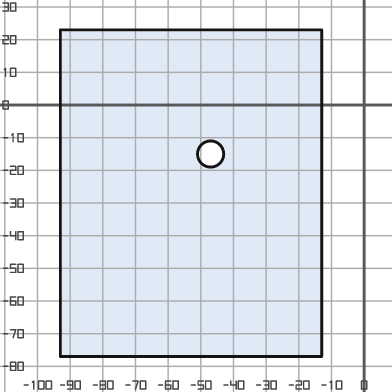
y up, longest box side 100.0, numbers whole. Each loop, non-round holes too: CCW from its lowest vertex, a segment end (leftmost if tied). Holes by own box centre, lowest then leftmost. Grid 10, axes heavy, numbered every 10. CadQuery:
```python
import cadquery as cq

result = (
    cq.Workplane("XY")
    .moveTo(-93.0, -77.0)
    .lineTo(-13.0, -77.0)
    .lineTo(-13.0, 23.0)
    .lineTo(-93.0, 23.0)
    .close()
    .moveTo(-47.0, -15.0)
    .circle(4.0)
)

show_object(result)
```